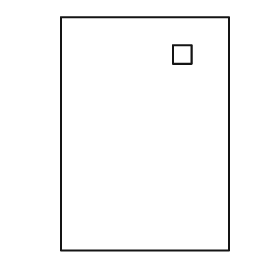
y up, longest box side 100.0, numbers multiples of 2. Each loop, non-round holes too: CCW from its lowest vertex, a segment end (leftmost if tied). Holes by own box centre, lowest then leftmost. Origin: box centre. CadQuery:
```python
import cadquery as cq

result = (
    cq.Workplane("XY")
    .moveTo(-36.0, -50.0)
    .lineTo(36.0, -50.0)
    .lineTo(36.0, 50.0)
    .lineTo(-36.0, 50.0)
    .close()
    .moveTo(12.0, 30.0)
    .lineTo(20.0, 30.0)
    .lineTo(20.0, 38.0)
    .lineTo(12.0, 38.0)
    .close()
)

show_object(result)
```